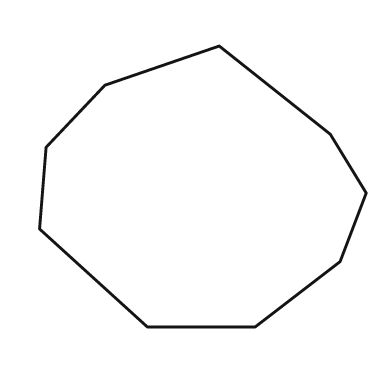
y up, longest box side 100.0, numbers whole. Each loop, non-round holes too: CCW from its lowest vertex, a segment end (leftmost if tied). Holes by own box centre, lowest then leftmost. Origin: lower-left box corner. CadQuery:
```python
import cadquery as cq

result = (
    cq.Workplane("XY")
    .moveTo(33.0, 0.0)
    .lineTo(66.0, 0.0)
    .lineTo(92.0, 20.0)
    .lineTo(100.0, 41.0)
    .lineTo(89.0, 59.0)
    .lineTo(55.0, 86.0)
    .lineTo(20.0, 74.0)
    .lineTo(2.0, 55.0)
    .lineTo(0.0, 30.0)
    .close()
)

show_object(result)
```